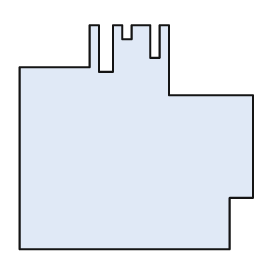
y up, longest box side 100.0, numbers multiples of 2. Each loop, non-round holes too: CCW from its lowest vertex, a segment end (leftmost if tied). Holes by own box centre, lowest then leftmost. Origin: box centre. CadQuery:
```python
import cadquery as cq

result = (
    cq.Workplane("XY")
    .moveTo(-50.0, -48.0)
    .lineTo(40.0, -48.0)
    .lineTo(40.0, -26.0)
    .lineTo(50.0, -26.0)
    .lineTo(50.0, 18.0)
    .lineTo(14.0, 18.0)
    .lineTo(14.0, 48.0)
    .lineTo(10.0, 48.0)
    .lineTo(10.0, 34.0)
    .lineTo(6.0, 34.0)
    .lineTo(6.0, 48.0)
    .lineTo(-2.0, 48.0)
    .lineTo(-2.0, 42.0)
    .lineTo(-6.0, 42.0)
    .lineTo(-6.0, 48.0)
    .lineTo(-10.0, 48.0)
    .lineTo(-10.0, 28.0)
    .lineTo(-16.0, 28.0)
    .lineTo(-16.0, 48.0)
    .lineTo(-20.0, 48.0)
    .lineTo(-20.0, 30.0)
    .lineTo(-50.0, 30.0)
    .close()
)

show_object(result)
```